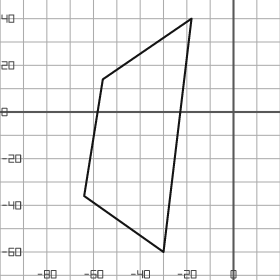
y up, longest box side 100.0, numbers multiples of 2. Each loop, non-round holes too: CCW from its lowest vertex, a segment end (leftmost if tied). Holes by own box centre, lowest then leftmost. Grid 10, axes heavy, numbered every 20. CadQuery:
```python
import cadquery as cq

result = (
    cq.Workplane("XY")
    .moveTo(-30.0, -60.0)
    .lineTo(-18.0, 40.0)
    .lineTo(-56.0, 14.0)
    .lineTo(-64.0, -36.0)
    .close()
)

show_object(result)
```